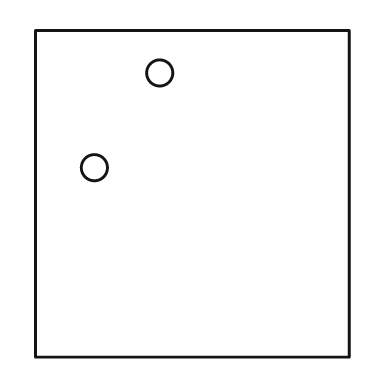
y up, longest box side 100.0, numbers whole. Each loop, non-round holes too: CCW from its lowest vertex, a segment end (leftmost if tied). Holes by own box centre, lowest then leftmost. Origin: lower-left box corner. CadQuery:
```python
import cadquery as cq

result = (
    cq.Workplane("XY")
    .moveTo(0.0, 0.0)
    .lineTo(96.0, 0.0)
    .lineTo(96.0, 100.0)
    .lineTo(0.0, 100.0)
    .close()
    .moveTo(18.0, 58.0)
    .circle(4.0)
    .moveTo(38.0, 87.0)
    .circle(4.0)
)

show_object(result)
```